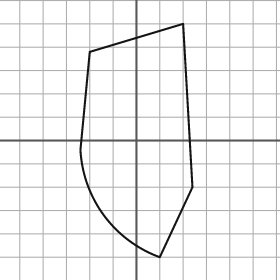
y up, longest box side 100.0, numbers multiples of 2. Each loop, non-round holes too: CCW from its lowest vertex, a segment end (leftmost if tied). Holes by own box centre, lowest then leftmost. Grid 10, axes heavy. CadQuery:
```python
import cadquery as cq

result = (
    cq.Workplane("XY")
    .moveTo(10.0, -50.0)
    .lineTo(24.0, -20.0)
    .lineTo(20.0, 50.0)
    .lineTo(-20.0, 38.0)
    .lineTo(-24.0, -4.0)
    .threePointArc((-14.0, -32.0), (10.0, -50.0))
    .close()
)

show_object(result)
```